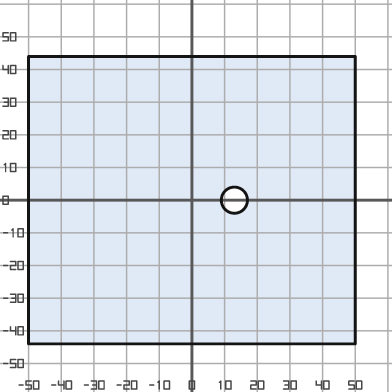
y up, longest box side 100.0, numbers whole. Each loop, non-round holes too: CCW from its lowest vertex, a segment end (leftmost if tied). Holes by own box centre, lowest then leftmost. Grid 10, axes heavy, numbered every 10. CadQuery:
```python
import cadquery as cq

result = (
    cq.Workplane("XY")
    .moveTo(-50.0, -44.0)
    .lineTo(50.0, -44.0)
    .lineTo(50.0, 44.0)
    .lineTo(-50.0, 44.0)
    .close()
    .moveTo(13.0, 0.0)
    .circle(4.0)
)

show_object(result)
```